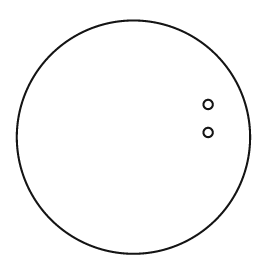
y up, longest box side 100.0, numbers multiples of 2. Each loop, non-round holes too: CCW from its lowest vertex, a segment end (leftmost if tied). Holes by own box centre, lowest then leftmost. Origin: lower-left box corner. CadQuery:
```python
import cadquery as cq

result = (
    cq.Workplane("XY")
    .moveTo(50.0, 50.0)
    .circle(50.0)
    .moveTo(82.0, 52.0)
    .circle(2.0)
    .moveTo(82.0, 64.0)
    .circle(2.0)
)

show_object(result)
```